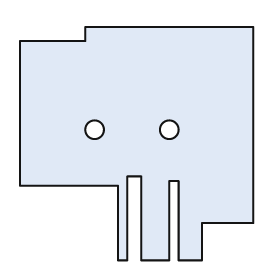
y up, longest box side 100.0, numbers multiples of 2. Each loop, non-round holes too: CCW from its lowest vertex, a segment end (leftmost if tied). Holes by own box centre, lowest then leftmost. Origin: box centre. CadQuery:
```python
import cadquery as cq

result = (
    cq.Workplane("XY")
    .moveTo(-8.0, -50.0)
    .lineTo(-4.0, -50.0)
    .lineTo(-4.0, -14.0)
    .lineTo(2.0, -14.0)
    .lineTo(2.0, -50.0)
    .lineTo(14.0, -50.0)
    .lineTo(14.0, -16.0)
    .lineTo(18.0, -16.0)
    .lineTo(18.0, -50.0)
    .lineTo(28.0, -50.0)
    .lineTo(28.0, -34.0)
    .lineTo(50.0, -34.0)
    .lineTo(50.0, 50.0)
    .lineTo(-22.0, 50.0)
    .lineTo(-22.0, 44.0)
    .lineTo(-50.0, 44.0)
    .lineTo(-50.0, -18.0)
    .lineTo(-8.0, -18.0)
    .close()
    .moveTo(-18.0, 6.0)
    .circle(4.0)
    .moveTo(14.0, 6.0)
    .circle(4.0)
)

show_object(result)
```